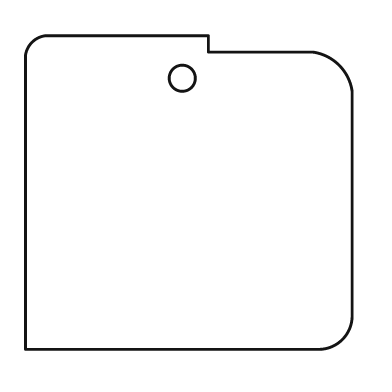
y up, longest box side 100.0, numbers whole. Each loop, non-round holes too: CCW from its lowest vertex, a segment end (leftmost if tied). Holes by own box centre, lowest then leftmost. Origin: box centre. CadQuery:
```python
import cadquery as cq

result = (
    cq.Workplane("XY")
    .moveTo(-50.0, -48.0)
    .lineTo(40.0, -48.0)
    .threePointArc((47.0, -45.0), (50.0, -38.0))
    .lineTo(50.0, 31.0)
    .threePointArc((46.0, 39.0), (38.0, 43.0))
    .lineTo(6.0, 43.0)
    .lineTo(6.0, 48.0)
    .lineTo(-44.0, 48.0)
    .threePointArc((-48.0, 46.0), (-50.0, 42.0))
    .close()
    .moveTo(-2.0, 35.0)
    .circle(4.0)
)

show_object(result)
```